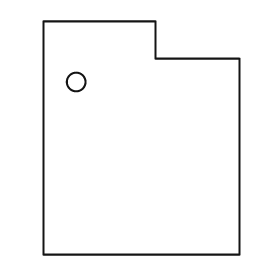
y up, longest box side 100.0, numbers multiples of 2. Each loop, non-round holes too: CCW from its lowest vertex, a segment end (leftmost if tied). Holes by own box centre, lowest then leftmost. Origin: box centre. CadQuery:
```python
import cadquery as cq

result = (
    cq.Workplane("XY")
    .moveTo(-42.0, -50.0)
    .lineTo(42.0, -50.0)
    .lineTo(42.0, 34.0)
    .lineTo(6.0, 34.0)
    .lineTo(6.0, 50.0)
    .lineTo(-42.0, 50.0)
    .close()
    .moveTo(-28.0, 24.0)
    .circle(4.0)
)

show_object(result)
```